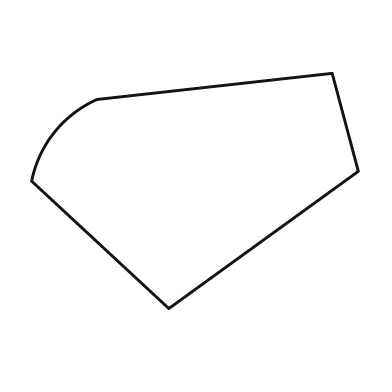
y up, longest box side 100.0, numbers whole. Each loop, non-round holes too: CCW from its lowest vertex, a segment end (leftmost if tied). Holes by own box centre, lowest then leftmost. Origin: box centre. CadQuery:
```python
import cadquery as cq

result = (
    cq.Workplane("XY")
    .moveTo(-8.0, -36.0)
    .lineTo(50.0, 6.0)
    .lineTo(42.0, 36.0)
    .lineTo(-30.0, 28.0)
    .threePointArc((-43.0, 18.0), (-50.0, 3.0))
    .close()
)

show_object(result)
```